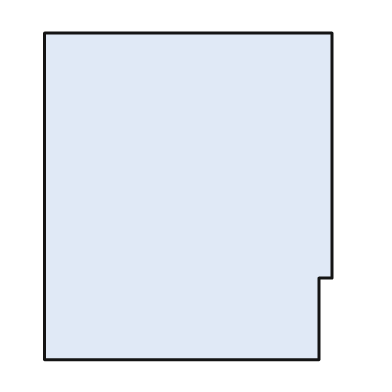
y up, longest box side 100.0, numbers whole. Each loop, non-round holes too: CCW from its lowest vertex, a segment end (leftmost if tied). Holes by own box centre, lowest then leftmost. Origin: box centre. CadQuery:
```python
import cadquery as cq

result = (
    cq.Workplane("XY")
    .moveTo(-44.0, -50.0)
    .lineTo(40.0, -50.0)
    .lineTo(40.0, -25.0)
    .lineTo(44.0, -25.0)
    .lineTo(44.0, 50.0)
    .lineTo(-44.0, 50.0)
    .close()
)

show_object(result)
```